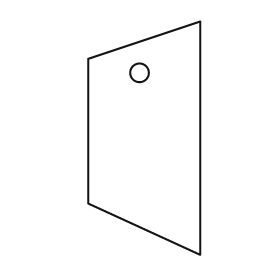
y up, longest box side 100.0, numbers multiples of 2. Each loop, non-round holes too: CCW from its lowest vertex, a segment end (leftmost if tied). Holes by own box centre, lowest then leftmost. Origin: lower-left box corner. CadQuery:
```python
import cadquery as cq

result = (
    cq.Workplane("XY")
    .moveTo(48.0, 0.0)
    .lineTo(48.0, 100.0)
    .lineTo(0.0, 84.0)
    .lineTo(0.0, 22.0)
    .close()
    .moveTo(22.0, 78.0)
    .circle(4.0)
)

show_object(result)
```